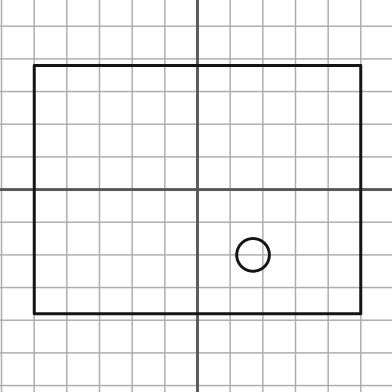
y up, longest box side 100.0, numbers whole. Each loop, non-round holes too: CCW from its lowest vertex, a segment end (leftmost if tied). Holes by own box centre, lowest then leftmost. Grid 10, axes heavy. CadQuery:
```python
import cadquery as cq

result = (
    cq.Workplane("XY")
    .moveTo(-50.0, -38.0)
    .lineTo(50.0, -38.0)
    .lineTo(50.0, 38.0)
    .lineTo(-50.0, 38.0)
    .close()
    .moveTo(17.0, -20.0)
    .circle(5.0)
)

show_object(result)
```